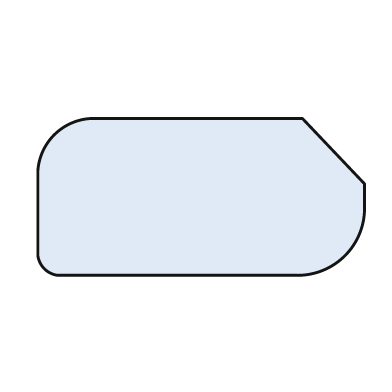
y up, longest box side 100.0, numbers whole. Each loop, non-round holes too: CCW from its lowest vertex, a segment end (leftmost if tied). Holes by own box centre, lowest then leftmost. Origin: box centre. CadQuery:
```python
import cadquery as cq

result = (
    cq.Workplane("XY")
    .moveTo(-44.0, -24.0)
    .lineTo(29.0, -24.0)
    .threePointArc((44.0, -18.0), (50.0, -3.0))
    .lineTo(50.0, 4.0)
    .lineTo(31.0, 24.0)
    .lineTo(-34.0, 24.0)
    .threePointArc((-45.0, 19.0), (-50.0, 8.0))
    .lineTo(-50.0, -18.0)
    .threePointArc((-48.0, -22.0), (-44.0, -24.0))
    .close()
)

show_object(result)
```